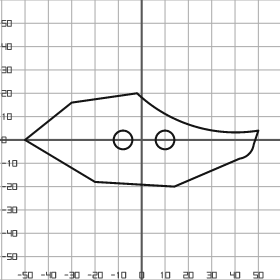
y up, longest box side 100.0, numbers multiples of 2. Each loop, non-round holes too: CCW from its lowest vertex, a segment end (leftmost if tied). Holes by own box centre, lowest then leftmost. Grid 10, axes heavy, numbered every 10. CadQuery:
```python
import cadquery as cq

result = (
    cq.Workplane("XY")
    .moveTo(14.0, -20.0)
    .lineTo(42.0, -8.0)
    .threePointArc((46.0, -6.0), (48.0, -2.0))
    .lineTo(50.0, 4.0)
    .threePointArc((22.0, 6.0), (-2.0, 20.0))
    .lineTo(-30.0, 16.0)
    .lineTo(-50.0, 0.0)
    .lineTo(-20.0, -18.0)
    .close()
    .moveTo(-8.0, 0.0)
    .circle(4.0)
    .moveTo(10.0, 0.0)
    .circle(4.0)
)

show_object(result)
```